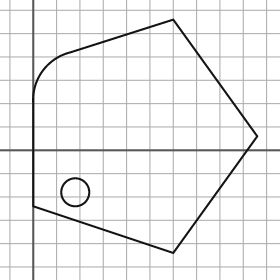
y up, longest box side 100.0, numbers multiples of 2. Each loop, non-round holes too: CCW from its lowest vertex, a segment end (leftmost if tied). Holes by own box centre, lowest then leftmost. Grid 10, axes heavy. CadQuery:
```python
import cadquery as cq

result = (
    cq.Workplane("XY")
    .moveTo(60.0, -44.0)
    .lineTo(96.0, 6.0)
    .lineTo(60.0, 56.0)
    .lineTo(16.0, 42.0)
    .threePointArc((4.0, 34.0), (0.0, 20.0))
    .lineTo(0.0, -24.0)
    .close()
    .moveTo(18.0, -18.0)
    .circle(6.0)
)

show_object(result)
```